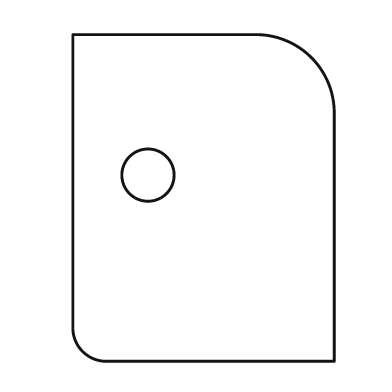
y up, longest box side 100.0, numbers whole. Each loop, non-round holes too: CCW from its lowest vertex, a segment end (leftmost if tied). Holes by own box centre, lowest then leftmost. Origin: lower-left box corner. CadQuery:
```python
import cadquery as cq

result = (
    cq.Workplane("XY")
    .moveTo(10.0, 0.0)
    .lineTo(80.0, 0.0)
    .lineTo(80.0, 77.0)
    .threePointArc((73.0, 93.0), (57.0, 100.0))
    .lineTo(0.0, 100.0)
    .lineTo(0.0, 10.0)
    .threePointArc((3.0, 3.0), (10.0, 0.0))
    .close()
    .moveTo(23.0, 57.0)
    .circle(8.0)
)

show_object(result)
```